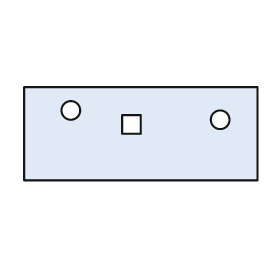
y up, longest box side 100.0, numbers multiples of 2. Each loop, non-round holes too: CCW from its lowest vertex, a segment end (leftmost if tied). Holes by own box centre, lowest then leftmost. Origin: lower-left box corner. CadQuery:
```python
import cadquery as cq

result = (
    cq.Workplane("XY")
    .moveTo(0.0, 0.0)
    .lineTo(100.0, 0.0)
    .lineTo(100.0, 40.0)
    .lineTo(0.0, 40.0)
    .close()
    .moveTo(42.0, 20.0)
    .lineTo(50.0, 20.0)
    .lineTo(50.0, 28.0)
    .lineTo(42.0, 28.0)
    .close()
    .moveTo(84.0, 26.0)
    .circle(4.0)
    .moveTo(20.0, 30.0)
    .circle(4.0)
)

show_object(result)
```